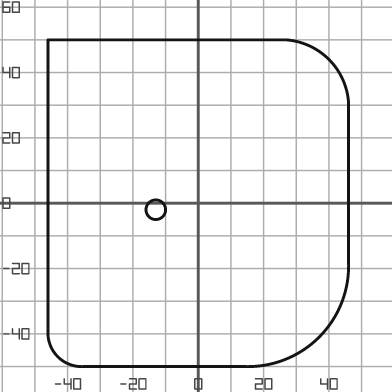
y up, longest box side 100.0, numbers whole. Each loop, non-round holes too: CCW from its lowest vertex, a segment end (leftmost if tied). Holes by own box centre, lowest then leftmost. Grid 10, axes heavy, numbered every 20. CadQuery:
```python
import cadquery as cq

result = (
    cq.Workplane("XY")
    .moveTo(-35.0, -50.0)
    .lineTo(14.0, -50.0)
    .threePointArc((37.0, -41.0), (46.0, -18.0))
    .lineTo(46.0, 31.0)
    .threePointArc((40.0, 44.0), (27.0, 50.0))
    .lineTo(-46.0, 50.0)
    .lineTo(-46.0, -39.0)
    .threePointArc((-43.0, -47.0), (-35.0, -50.0))
    .close()
    .moveTo(-13.0, -2.0)
    .circle(3.0)
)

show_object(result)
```